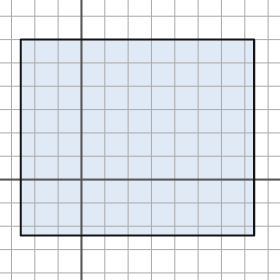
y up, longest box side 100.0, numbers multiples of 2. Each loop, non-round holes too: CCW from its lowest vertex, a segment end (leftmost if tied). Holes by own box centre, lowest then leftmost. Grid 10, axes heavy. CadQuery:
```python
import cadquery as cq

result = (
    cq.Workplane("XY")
    .moveTo(-26.0, -24.0)
    .lineTo(74.0, -24.0)
    .lineTo(74.0, 60.0)
    .lineTo(-26.0, 60.0)
    .close()
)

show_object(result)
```